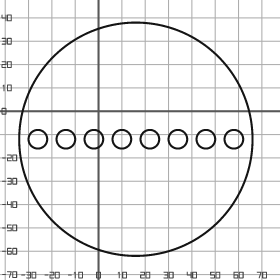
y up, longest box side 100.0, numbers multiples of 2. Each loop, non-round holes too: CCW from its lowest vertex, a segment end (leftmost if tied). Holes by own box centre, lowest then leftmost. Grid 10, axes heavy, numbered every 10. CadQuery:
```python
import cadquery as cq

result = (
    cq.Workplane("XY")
    .moveTo(16.0, -12.0)
    .circle(50.0)
    .moveTo(-26.0, -12.0)
    .circle(4.0)
    .moveTo(-14.0, -12.0)
    .circle(4.0)
    .moveTo(-2.0, -12.0)
    .circle(4.0)
    .moveTo(10.0, -12.0)
    .circle(4.0)
    .moveTo(22.0, -12.0)
    .circle(4.0)
    .moveTo(34.0, -12.0)
    .circle(4.0)
    .moveTo(46.0, -12.0)
    .circle(4.0)
    .moveTo(58.0, -12.0)
    .circle(4.0)
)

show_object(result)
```